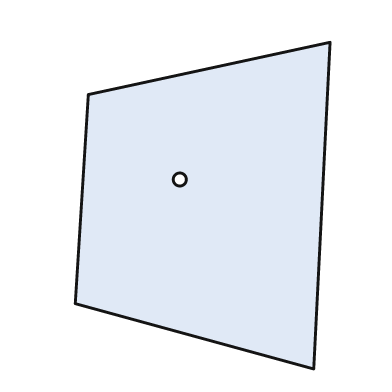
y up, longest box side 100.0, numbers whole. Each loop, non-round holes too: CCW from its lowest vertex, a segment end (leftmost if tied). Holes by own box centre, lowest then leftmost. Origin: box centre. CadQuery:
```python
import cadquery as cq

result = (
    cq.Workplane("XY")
    .moveTo(34.0, -50.0)
    .lineTo(39.0, 50.0)
    .lineTo(-35.0, 34.0)
    .lineTo(-39.0, -30.0)
    .close()
    .moveTo(-7.0, 8.0)
    .circle(2.0)
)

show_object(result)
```